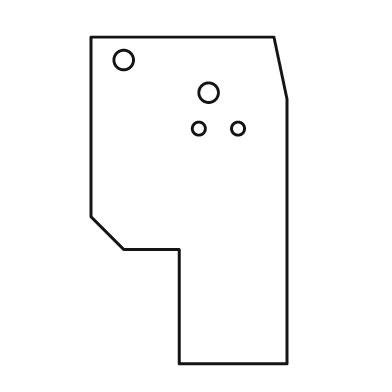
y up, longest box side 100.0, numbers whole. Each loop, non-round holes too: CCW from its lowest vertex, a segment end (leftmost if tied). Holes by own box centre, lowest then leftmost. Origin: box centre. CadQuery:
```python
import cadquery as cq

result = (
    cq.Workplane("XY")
    .moveTo(-3.0, -50.0)
    .lineTo(30.0, -50.0)
    .lineTo(30.0, 31.0)
    .lineTo(26.0, 50.0)
    .lineTo(-30.0, 50.0)
    .lineTo(-30.0, -5.0)
    .lineTo(-20.0, -15.0)
    .lineTo(-3.0, -15.0)
    .close()
    .moveTo(3.0, 22.0)
    .circle(2.0)
    .moveTo(15.0, 22.0)
    .circle(2.0)
    .moveTo(6.0, 33.0)
    .circle(3.0)
    .moveTo(-20.0, 43.0)
    .circle(3.0)
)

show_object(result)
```